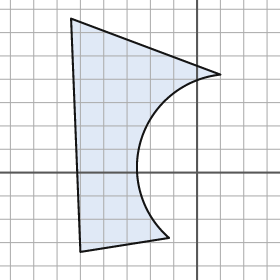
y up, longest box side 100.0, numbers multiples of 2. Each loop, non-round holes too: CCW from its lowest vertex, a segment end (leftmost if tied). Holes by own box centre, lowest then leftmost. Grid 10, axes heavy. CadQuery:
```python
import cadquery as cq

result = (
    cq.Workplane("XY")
    .moveTo(-50.0, -34.0)
    .lineTo(-12.0, -28.0)
    .threePointArc((-24.0, 14.0), (10.0, 42.0))
    .lineTo(-54.0, 66.0)
    .close()
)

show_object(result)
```